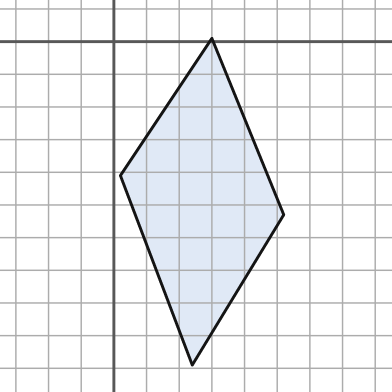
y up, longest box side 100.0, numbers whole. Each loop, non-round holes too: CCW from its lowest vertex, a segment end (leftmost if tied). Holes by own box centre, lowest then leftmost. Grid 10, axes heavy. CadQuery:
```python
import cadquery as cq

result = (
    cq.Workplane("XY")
    .moveTo(24.0, -99.0)
    .lineTo(52.0, -53.0)
    .lineTo(30.0, 1.0)
    .lineTo(2.0, -41.0)
    .close()
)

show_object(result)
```